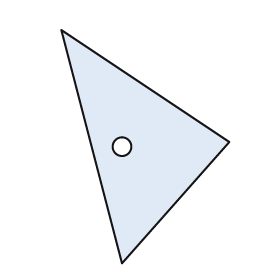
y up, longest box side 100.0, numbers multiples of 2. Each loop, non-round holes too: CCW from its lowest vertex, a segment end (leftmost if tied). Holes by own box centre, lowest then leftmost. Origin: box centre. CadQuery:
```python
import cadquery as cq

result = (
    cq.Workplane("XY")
    .moveTo(-10.0, -50.0)
    .lineTo(36.0, 2.0)
    .lineTo(-36.0, 50.0)
    .close()
    .moveTo(-10.0, 0.0)
    .circle(4.0)
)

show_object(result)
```